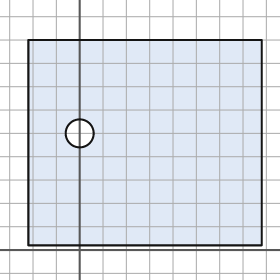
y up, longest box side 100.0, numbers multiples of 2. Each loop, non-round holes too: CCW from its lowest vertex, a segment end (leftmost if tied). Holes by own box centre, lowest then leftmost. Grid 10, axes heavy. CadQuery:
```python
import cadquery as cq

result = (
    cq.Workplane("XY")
    .moveTo(-22.0, 2.0)
    .lineTo(78.0, 2.0)
    .lineTo(78.0, 90.0)
    .lineTo(-22.0, 90.0)
    .close()
    .moveTo(0.0, 50.0)
    .circle(6.0)
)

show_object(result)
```